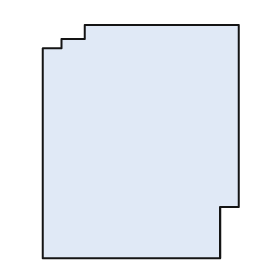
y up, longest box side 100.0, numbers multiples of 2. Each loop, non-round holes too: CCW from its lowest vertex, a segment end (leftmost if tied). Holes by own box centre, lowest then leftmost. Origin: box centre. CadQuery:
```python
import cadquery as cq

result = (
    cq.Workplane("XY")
    .moveTo(-42.0, -50.0)
    .lineTo(34.0, -50.0)
    .lineTo(34.0, -28.0)
    .lineTo(42.0, -28.0)
    .lineTo(42.0, 50.0)
    .lineTo(-24.0, 50.0)
    .lineTo(-24.0, 44.0)
    .lineTo(-34.0, 44.0)
    .lineTo(-34.0, 40.0)
    .lineTo(-42.0, 40.0)
    .close()
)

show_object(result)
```